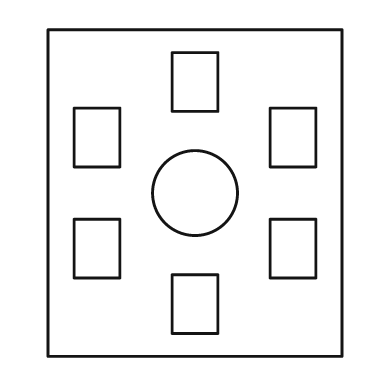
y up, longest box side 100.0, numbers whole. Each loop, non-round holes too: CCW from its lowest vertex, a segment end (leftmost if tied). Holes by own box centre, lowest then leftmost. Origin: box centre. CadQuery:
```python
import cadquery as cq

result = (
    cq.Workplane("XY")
    .moveTo(-45.0, -50.0)
    .lineTo(45.0, -50.0)
    .lineTo(45.0, 50.0)
    .lineTo(-45.0, 50.0)
    .close()
    .moveTo(-7.0, -43.0)
    .lineTo(7.0, -43.0)
    .lineTo(7.0, -25.0)
    .lineTo(-7.0, -25.0)
    .close()
    .moveTo(-37.0, -26.0)
    .lineTo(-23.0, -26.0)
    .lineTo(-23.0, -8.0)
    .lineTo(-37.0, -8.0)
    .close()
    .moveTo(23.0, -26.0)
    .lineTo(37.0, -26.0)
    .lineTo(37.0, -8.0)
    .lineTo(23.0, -8.0)
    .close()
    .moveTo(0.0, 0.0)
    .circle(13.0)
    .moveTo(-37.0, 8.0)
    .lineTo(-23.0, 8.0)
    .lineTo(-23.0, 26.0)
    .lineTo(-37.0, 26.0)
    .close()
    .moveTo(23.0, 8.0)
    .lineTo(37.0, 8.0)
    .lineTo(37.0, 26.0)
    .lineTo(23.0, 26.0)
    .close()
    .moveTo(-7.0, 25.0)
    .lineTo(7.0, 25.0)
    .lineTo(7.0, 43.0)
    .lineTo(-7.0, 43.0)
    .close()
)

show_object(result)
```